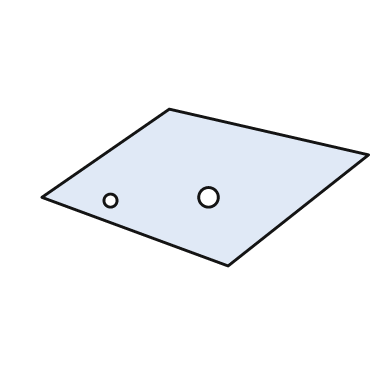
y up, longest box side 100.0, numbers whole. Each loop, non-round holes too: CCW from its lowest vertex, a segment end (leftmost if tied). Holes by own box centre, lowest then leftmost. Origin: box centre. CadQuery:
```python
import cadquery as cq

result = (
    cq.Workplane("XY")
    .moveTo(7.0, -24.0)
    .lineTo(50.0, 10.0)
    .lineTo(-11.0, 24.0)
    .lineTo(-50.0, -3.0)
    .close()
    .moveTo(-29.0, -4.0)
    .circle(2.0)
    .moveTo(1.0, -3.0)
    .circle(3.0)
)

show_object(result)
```